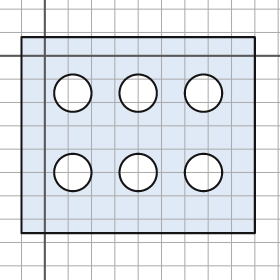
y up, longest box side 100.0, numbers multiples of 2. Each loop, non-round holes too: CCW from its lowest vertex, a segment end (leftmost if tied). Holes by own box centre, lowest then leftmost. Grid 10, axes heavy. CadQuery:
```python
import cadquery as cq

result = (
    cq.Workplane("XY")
    .moveTo(-10.0, -76.0)
    .lineTo(90.0, -76.0)
    .lineTo(90.0, 8.0)
    .lineTo(-10.0, 8.0)
    .close()
    .moveTo(12.0, -50.0)
    .circle(8.0)
    .moveTo(40.0, -50.0)
    .circle(8.0)
    .moveTo(68.0, -50.0)
    .circle(8.0)
    .moveTo(12.0, -16.0)
    .circle(8.0)
    .moveTo(40.0, -16.0)
    .circle(8.0)
    .moveTo(68.0, -16.0)
    .circle(8.0)
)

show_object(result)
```